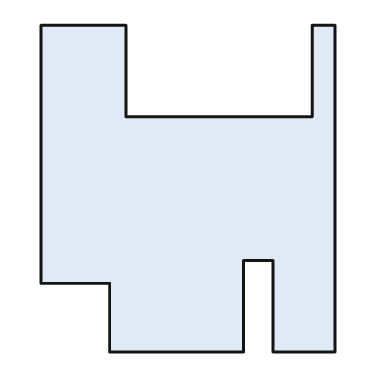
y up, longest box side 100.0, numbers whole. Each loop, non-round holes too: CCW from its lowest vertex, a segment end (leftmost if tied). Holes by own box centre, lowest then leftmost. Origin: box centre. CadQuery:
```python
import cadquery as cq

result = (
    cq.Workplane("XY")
    .moveTo(-24.0, -50.0)
    .lineTo(17.0, -50.0)
    .lineTo(17.0, -22.0)
    .lineTo(26.0, -22.0)
    .lineTo(26.0, -50.0)
    .lineTo(45.0, -50.0)
    .lineTo(45.0, 50.0)
    .lineTo(38.0, 50.0)
    .lineTo(38.0, 22.0)
    .lineTo(-19.0, 22.0)
    .lineTo(-19.0, 50.0)
    .lineTo(-45.0, 50.0)
    .lineTo(-45.0, -29.0)
    .lineTo(-24.0, -29.0)
    .close()
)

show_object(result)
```